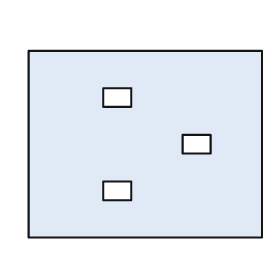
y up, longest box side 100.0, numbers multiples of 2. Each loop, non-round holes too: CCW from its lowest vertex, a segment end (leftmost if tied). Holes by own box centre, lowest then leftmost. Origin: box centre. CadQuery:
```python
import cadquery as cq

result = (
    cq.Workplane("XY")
    .moveTo(-50.0, -40.0)
    .lineTo(50.0, -40.0)
    .lineTo(50.0, 40.0)
    .lineTo(-50.0, 40.0)
    .close()
    .moveTo(-18.0, -24.0)
    .lineTo(-6.0, -24.0)
    .lineTo(-6.0, -16.0)
    .lineTo(-18.0, -16.0)
    .close()
    .moveTo(16.0, -4.0)
    .lineTo(28.0, -4.0)
    .lineTo(28.0, 4.0)
    .lineTo(16.0, 4.0)
    .close()
    .moveTo(-18.0, 16.0)
    .lineTo(-6.0, 16.0)
    .lineTo(-6.0, 24.0)
    .lineTo(-18.0, 24.0)
    .close()
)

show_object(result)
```